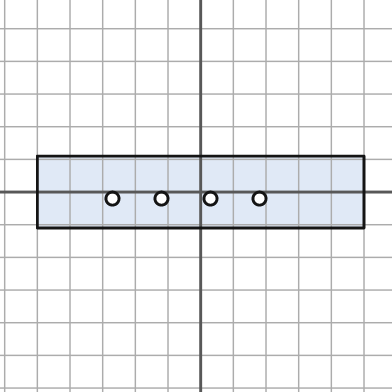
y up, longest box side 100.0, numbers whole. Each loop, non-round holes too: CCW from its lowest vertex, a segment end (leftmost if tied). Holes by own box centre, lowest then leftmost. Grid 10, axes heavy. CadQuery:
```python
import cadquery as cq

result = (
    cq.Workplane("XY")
    .moveTo(-50.0, -11.0)
    .lineTo(50.0, -11.0)
    .lineTo(50.0, 11.0)
    .lineTo(-50.0, 11.0)
    .close()
    .moveTo(-27.0, -2.0)
    .circle(2.0)
    .moveTo(-12.0, -2.0)
    .circle(2.0)
    .moveTo(3.0, -2.0)
    .circle(2.0)
    .moveTo(18.0, -2.0)
    .circle(2.0)
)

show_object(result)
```